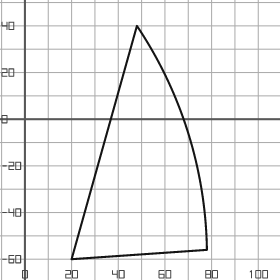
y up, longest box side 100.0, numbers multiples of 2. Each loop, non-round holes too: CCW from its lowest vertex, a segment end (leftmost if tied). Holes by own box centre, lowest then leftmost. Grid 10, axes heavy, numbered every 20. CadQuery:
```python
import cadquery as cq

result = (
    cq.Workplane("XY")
    .moveTo(20.0, -60.0)
    .lineTo(78.0, -56.0)
    .threePointArc((70.0, -6.0), (48.0, 40.0))
    .close()
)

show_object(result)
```